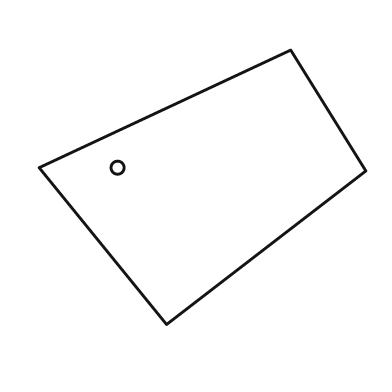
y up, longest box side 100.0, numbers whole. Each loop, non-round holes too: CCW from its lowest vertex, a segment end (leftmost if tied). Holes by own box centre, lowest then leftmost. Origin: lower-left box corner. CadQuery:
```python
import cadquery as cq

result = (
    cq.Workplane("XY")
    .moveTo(39.0, 0.0)
    .lineTo(100.0, 47.0)
    .lineTo(77.0, 84.0)
    .lineTo(0.0, 48.0)
    .close()
    .moveTo(24.0, 48.0)
    .circle(2.0)
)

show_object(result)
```